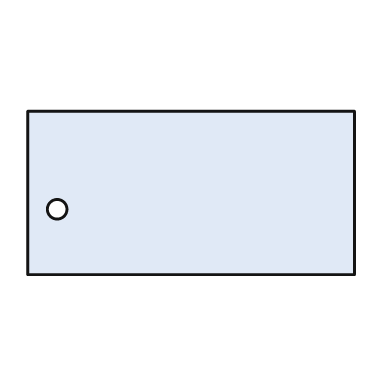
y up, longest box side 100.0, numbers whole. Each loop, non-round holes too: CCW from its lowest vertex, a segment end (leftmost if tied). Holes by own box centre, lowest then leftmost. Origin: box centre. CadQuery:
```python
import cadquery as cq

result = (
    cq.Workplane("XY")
    .moveTo(-50.0, -25.0)
    .lineTo(50.0, -25.0)
    .lineTo(50.0, 25.0)
    .lineTo(-50.0, 25.0)
    .close()
    .moveTo(-41.0, -5.0)
    .circle(3.0)
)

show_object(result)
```